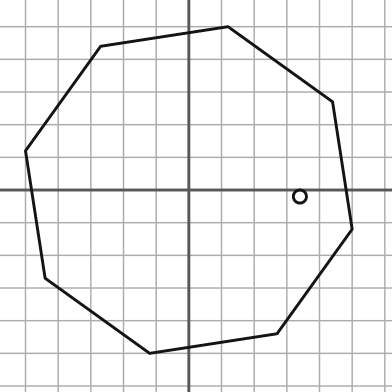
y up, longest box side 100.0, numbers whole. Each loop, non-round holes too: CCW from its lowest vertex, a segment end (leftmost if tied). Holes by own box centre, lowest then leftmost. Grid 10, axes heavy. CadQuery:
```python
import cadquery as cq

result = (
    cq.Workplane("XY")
    .moveTo(-12.0, -50.0)
    .lineTo(27.0, -44.0)
    .lineTo(50.0, -12.0)
    .lineTo(44.0, 27.0)
    .lineTo(12.0, 50.0)
    .lineTo(-27.0, 44.0)
    .lineTo(-50.0, 12.0)
    .lineTo(-44.0, -27.0)
    .close()
    .moveTo(34.0, -2.0)
    .circle(2.0)
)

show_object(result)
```